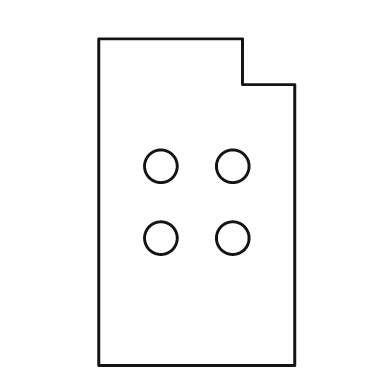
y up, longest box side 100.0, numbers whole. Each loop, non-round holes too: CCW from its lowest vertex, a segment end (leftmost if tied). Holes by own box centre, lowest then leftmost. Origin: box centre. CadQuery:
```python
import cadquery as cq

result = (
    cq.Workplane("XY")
    .moveTo(-30.0, -50.0)
    .lineTo(30.0, -50.0)
    .lineTo(30.0, 36.0)
    .lineTo(14.0, 36.0)
    .lineTo(14.0, 50.0)
    .lineTo(-30.0, 50.0)
    .close()
    .moveTo(-11.0, -11.0)
    .circle(5.0)
    .moveTo(11.0, -11.0)
    .circle(5.0)
    .moveTo(-11.0, 11.0)
    .circle(5.0)
    .moveTo(11.0, 11.0)
    .circle(5.0)
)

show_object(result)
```